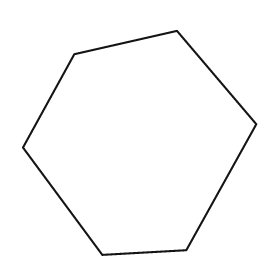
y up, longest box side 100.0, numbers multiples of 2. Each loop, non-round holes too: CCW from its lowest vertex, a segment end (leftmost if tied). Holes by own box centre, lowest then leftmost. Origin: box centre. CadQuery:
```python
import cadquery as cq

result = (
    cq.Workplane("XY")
    .moveTo(-16.0, -48.0)
    .lineTo(20.0, -46.0)
    .lineTo(50.0, 8.0)
    .lineTo(16.0, 48.0)
    .lineTo(-28.0, 38.0)
    .lineTo(-50.0, -2.0)
    .close()
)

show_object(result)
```